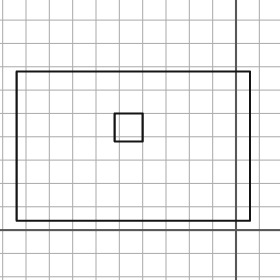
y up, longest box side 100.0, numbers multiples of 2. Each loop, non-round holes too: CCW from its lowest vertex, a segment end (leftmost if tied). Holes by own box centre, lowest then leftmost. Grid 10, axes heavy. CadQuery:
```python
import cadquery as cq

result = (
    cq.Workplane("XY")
    .moveTo(-94.0, 4.0)
    .lineTo(6.0, 4.0)
    .lineTo(6.0, 68.0)
    .lineTo(-94.0, 68.0)
    .close()
    .moveTo(-52.0, 38.0)
    .lineTo(-40.0, 38.0)
    .lineTo(-40.0, 50.0)
    .lineTo(-52.0, 50.0)
    .close()
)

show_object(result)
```